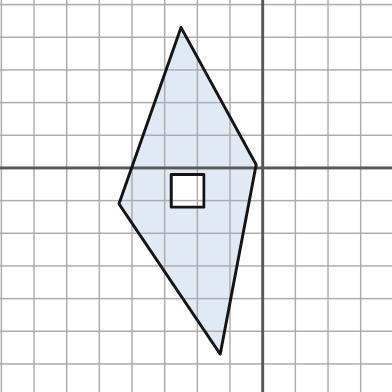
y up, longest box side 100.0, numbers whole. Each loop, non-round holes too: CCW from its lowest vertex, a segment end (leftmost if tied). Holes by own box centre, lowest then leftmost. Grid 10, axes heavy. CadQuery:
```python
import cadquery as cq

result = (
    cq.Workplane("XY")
    .moveTo(-13.0, -57.0)
    .lineTo(-2.0, 1.0)
    .lineTo(-25.0, 43.0)
    .lineTo(-44.0, -11.0)
    .close()
    .moveTo(-28.0, -12.0)
    .lineTo(-18.0, -12.0)
    .lineTo(-18.0, -2.0)
    .lineTo(-28.0, -2.0)
    .close()
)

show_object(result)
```